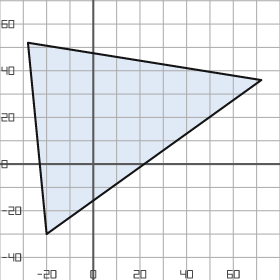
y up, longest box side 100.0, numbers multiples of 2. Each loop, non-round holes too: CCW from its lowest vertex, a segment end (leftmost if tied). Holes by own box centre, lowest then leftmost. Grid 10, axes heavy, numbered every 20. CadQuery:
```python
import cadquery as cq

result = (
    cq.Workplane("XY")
    .moveTo(-20.0, -30.0)
    .lineTo(72.0, 36.0)
    .lineTo(-28.0, 52.0)
    .close()
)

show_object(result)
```